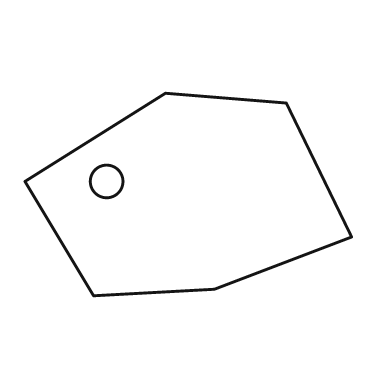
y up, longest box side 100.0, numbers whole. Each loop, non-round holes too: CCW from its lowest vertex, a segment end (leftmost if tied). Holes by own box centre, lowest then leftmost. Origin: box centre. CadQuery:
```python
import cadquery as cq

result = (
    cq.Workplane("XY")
    .moveTo(-29.0, -31.0)
    .lineTo(8.0, -29.0)
    .lineTo(50.0, -13.0)
    .lineTo(30.0, 28.0)
    .lineTo(-7.0, 31.0)
    .lineTo(-50.0, 4.0)
    .close()
    .moveTo(-25.0, 4.0)
    .circle(5.0)
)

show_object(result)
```